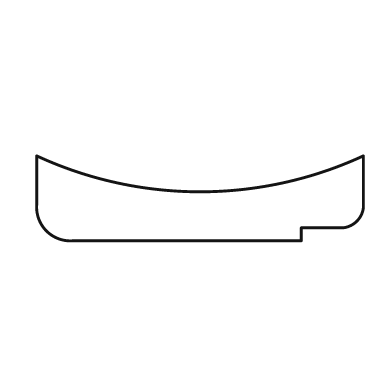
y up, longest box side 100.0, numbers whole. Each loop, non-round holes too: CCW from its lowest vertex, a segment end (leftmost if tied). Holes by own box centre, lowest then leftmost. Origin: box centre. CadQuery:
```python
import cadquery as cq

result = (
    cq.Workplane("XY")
    .moveTo(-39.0, -13.0)
    .lineTo(31.0, -13.0)
    .lineTo(31.0, -9.0)
    .lineTo(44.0, -9.0)
    .threePointArc((48.0, -7.0), (50.0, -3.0))
    .lineTo(50.0, 13.0)
    .threePointArc((0.0, 2.0), (-50.0, 13.0))
    .lineTo(-50.0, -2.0)
    .threePointArc((-47.0, -10.0), (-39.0, -13.0))
    .close()
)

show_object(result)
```